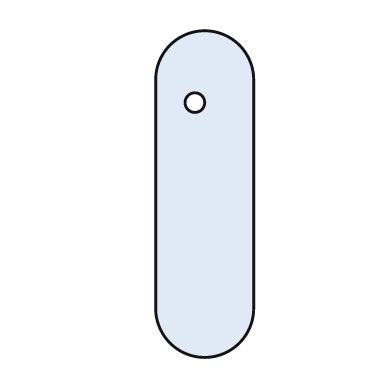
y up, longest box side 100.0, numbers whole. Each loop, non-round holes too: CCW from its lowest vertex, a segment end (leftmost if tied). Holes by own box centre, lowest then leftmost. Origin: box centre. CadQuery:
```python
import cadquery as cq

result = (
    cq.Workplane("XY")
    .moveTo(-15.0, -35.0)
    .threePointArc((0.0, -50.0), (15.0, -35.0))
    .lineTo(15.0, 35.0)
    .threePointArc((0.0, 50.0), (-15.0, 35.0))
    .close()
    .moveTo(-3.0, 28.0)
    .circle(3.0)
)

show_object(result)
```